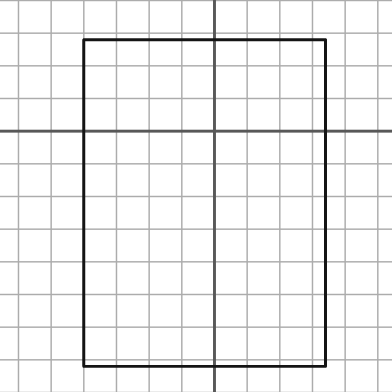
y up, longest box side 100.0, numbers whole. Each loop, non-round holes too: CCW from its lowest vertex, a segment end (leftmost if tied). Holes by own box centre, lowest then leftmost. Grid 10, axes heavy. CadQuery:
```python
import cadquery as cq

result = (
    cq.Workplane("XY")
    .moveTo(-40.0, -72.0)
    .lineTo(34.0, -72.0)
    .lineTo(34.0, 28.0)
    .lineTo(-40.0, 28.0)
    .close()
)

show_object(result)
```